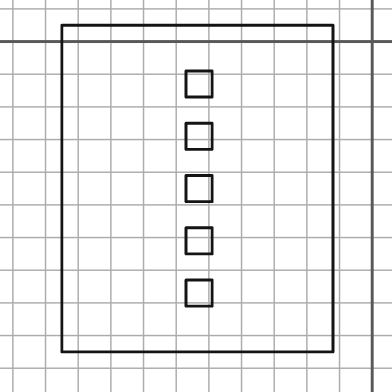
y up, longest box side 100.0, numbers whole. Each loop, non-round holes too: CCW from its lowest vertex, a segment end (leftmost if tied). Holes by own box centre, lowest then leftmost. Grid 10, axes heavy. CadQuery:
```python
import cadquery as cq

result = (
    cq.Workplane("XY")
    .moveTo(-95.0, -95.0)
    .lineTo(-12.0, -95.0)
    .lineTo(-12.0, 5.0)
    .lineTo(-95.0, 5.0)
    .close()
    .moveTo(-57.0, -81.0)
    .lineTo(-49.0, -81.0)
    .lineTo(-49.0, -73.0)
    .lineTo(-57.0, -73.0)
    .close()
    .moveTo(-57.0, -65.0)
    .lineTo(-49.0, -65.0)
    .lineTo(-49.0, -57.0)
    .lineTo(-57.0, -57.0)
    .close()
    .moveTo(-57.0, -49.0)
    .lineTo(-49.0, -49.0)
    .lineTo(-49.0, -41.0)
    .lineTo(-57.0, -41.0)
    .close()
    .moveTo(-57.0, -33.0)
    .lineTo(-49.0, -33.0)
    .lineTo(-49.0, -25.0)
    .lineTo(-57.0, -25.0)
    .close()
    .moveTo(-57.0, -17.0)
    .lineTo(-49.0, -17.0)
    .lineTo(-49.0, -9.0)
    .lineTo(-57.0, -9.0)
    .close()
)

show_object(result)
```